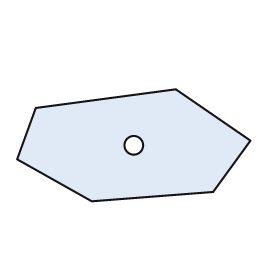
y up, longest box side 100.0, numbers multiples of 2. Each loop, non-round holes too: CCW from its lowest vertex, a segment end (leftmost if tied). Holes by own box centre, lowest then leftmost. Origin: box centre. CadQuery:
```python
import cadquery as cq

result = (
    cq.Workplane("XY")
    .moveTo(-18.0, -24.0)
    .lineTo(34.0, -20.0)
    .lineTo(50.0, 2.0)
    .lineTo(18.0, 24.0)
    .lineTo(-42.0, 16.0)
    .lineTo(-50.0, -6.0)
    .close()
    .moveTo(0.0, 0.0)
    .circle(4.0)
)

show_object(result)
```